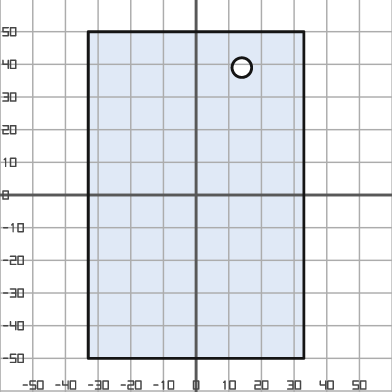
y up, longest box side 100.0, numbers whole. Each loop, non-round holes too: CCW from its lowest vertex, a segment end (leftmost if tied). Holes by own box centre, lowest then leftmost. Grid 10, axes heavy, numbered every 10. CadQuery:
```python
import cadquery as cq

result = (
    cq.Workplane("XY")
    .moveTo(-33.0, -50.0)
    .lineTo(33.0, -50.0)
    .lineTo(33.0, 50.0)
    .lineTo(-33.0, 50.0)
    .close()
    .moveTo(14.0, 39.0)
    .circle(3.0)
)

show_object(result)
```